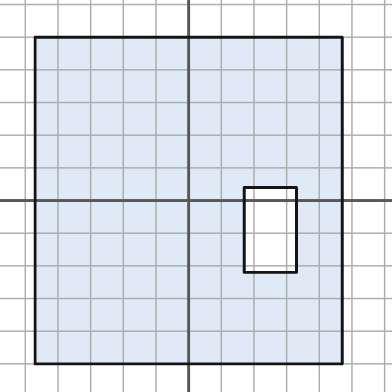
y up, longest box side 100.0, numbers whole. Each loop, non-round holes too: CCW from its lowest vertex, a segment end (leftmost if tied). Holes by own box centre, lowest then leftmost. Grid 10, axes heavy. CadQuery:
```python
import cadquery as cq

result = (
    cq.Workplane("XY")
    .moveTo(-47.0, -50.0)
    .lineTo(47.0, -50.0)
    .lineTo(47.0, 50.0)
    .lineTo(-47.0, 50.0)
    .close()
    .moveTo(17.0, -22.0)
    .lineTo(33.0, -22.0)
    .lineTo(33.0, 4.0)
    .lineTo(17.0, 4.0)
    .close()
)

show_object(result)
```